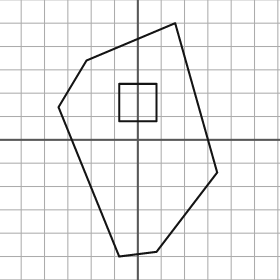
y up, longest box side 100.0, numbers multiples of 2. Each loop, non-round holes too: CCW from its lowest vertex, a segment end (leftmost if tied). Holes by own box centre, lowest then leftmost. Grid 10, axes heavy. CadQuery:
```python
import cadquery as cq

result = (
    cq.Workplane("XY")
    .moveTo(-8.0, -50.0)
    .lineTo(8.0, -48.0)
    .lineTo(34.0, -14.0)
    .lineTo(16.0, 50.0)
    .lineTo(-22.0, 34.0)
    .lineTo(-34.0, 14.0)
    .close()
    .moveTo(-8.0, 8.0)
    .lineTo(8.0, 8.0)
    .lineTo(8.0, 24.0)
    .lineTo(-8.0, 24.0)
    .close()
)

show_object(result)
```